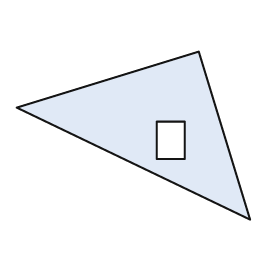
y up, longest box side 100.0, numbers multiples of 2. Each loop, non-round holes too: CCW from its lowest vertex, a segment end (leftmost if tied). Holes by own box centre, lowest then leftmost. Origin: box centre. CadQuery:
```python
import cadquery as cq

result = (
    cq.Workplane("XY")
    .moveTo(50.0, -36.0)
    .lineTo(28.0, 36.0)
    .lineTo(-50.0, 12.0)
    .close()
    .moveTo(10.0, -10.0)
    .lineTo(22.0, -10.0)
    .lineTo(22.0, 6.0)
    .lineTo(10.0, 6.0)
    .close()
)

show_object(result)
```